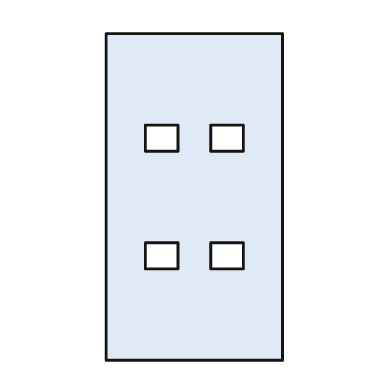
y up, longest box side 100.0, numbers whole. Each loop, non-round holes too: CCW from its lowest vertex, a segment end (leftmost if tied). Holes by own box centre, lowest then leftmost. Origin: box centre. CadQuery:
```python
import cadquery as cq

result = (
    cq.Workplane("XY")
    .moveTo(-27.0, -50.0)
    .lineTo(27.0, -50.0)
    .lineTo(27.0, 50.0)
    .lineTo(-27.0, 50.0)
    .close()
    .moveTo(-15.0, -22.0)
    .lineTo(-5.0, -22.0)
    .lineTo(-5.0, -14.0)
    .lineTo(-15.0, -14.0)
    .close()
    .moveTo(5.0, -22.0)
    .lineTo(15.0, -22.0)
    .lineTo(15.0, -14.0)
    .lineTo(5.0, -14.0)
    .close()
    .moveTo(-15.0, 14.0)
    .lineTo(-5.0, 14.0)
    .lineTo(-5.0, 22.0)
    .lineTo(-15.0, 22.0)
    .close()
    .moveTo(5.0, 14.0)
    .lineTo(15.0, 14.0)
    .lineTo(15.0, 22.0)
    .lineTo(5.0, 22.0)
    .close()
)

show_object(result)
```